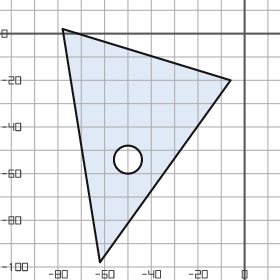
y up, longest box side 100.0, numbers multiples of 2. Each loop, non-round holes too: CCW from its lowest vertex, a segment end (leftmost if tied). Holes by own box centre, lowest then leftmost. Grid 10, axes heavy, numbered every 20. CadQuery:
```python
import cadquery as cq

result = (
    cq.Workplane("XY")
    .moveTo(-62.0, -98.0)
    .lineTo(-6.0, -20.0)
    .lineTo(-78.0, 2.0)
    .close()
    .moveTo(-50.0, -54.0)
    .circle(6.0)
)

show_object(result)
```